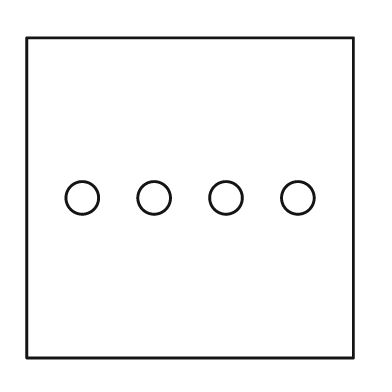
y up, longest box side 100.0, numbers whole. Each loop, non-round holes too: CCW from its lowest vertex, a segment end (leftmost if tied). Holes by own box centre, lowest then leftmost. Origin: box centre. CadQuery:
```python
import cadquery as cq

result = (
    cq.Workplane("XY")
    .moveTo(-50.0, -49.0)
    .lineTo(50.0, -49.0)
    .lineTo(50.0, 49.0)
    .lineTo(-50.0, 49.0)
    .close()
    .moveTo(-33.0, 0.0)
    .circle(5.0)
    .moveTo(-11.0, 0.0)
    .circle(5.0)
    .moveTo(11.0, 0.0)
    .circle(5.0)
    .moveTo(33.0, 0.0)
    .circle(5.0)
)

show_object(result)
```